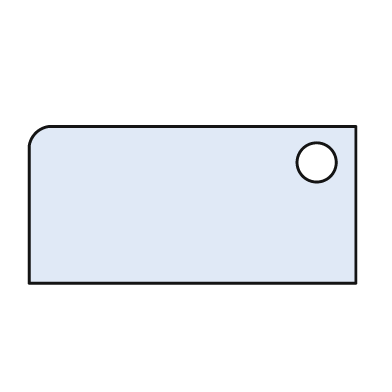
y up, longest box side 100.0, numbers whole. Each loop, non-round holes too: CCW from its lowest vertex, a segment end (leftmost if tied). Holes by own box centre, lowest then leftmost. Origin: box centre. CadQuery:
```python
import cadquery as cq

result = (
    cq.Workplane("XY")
    .moveTo(-50.0, -24.0)
    .lineTo(50.0, -24.0)
    .lineTo(50.0, 24.0)
    .lineTo(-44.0, 24.0)
    .threePointArc((-48.0, 22.0), (-50.0, 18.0))
    .close()
    .moveTo(38.0, 13.0)
    .circle(6.0)
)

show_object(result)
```